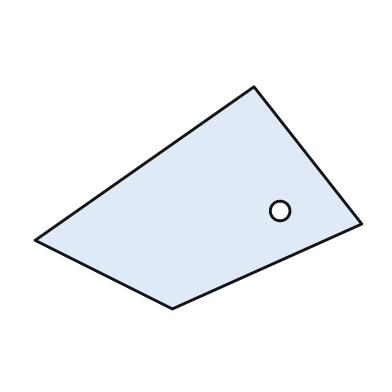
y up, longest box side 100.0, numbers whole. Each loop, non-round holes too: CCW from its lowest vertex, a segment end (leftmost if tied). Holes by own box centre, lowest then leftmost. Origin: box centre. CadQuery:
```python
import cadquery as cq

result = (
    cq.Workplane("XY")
    .moveTo(-8.0, -34.0)
    .lineTo(50.0, -8.0)
    .lineTo(17.0, 34.0)
    .lineTo(-50.0, -13.0)
    .close()
    .moveTo(25.0, -4.0)
    .circle(3.0)
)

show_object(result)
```